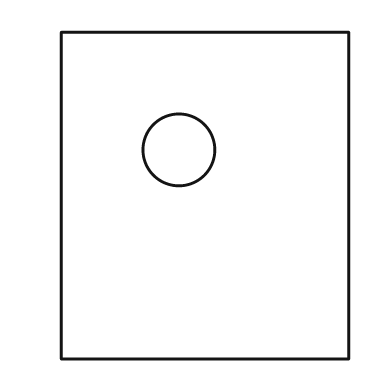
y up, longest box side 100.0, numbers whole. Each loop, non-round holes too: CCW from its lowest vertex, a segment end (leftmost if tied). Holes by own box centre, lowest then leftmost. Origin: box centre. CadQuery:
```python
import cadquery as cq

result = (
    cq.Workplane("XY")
    .moveTo(-44.0, -50.0)
    .lineTo(44.0, -50.0)
    .lineTo(44.0, 50.0)
    .lineTo(-44.0, 50.0)
    .close()
    .moveTo(-8.0, 14.0)
    .circle(11.0)
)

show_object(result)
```